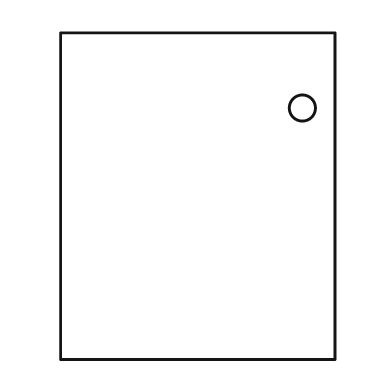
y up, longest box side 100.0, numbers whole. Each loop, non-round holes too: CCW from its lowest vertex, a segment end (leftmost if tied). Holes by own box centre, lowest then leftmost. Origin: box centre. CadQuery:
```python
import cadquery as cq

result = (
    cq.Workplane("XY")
    .moveTo(-42.0, -50.0)
    .lineTo(42.0, -50.0)
    .lineTo(42.0, 50.0)
    .lineTo(-42.0, 50.0)
    .close()
    .moveTo(32.0, 27.0)
    .circle(4.0)
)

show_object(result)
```